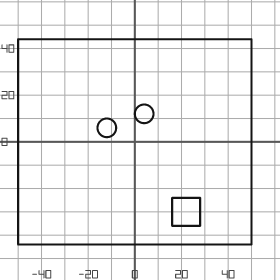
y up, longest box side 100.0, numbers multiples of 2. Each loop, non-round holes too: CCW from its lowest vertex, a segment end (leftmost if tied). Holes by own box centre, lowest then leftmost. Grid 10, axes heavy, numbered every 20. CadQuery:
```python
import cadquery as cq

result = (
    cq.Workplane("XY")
    .moveTo(-50.0, -44.0)
    .lineTo(50.0, -44.0)
    .lineTo(50.0, 44.0)
    .lineTo(-50.0, 44.0)
    .close()
    .moveTo(16.0, -36.0)
    .lineTo(28.0, -36.0)
    .lineTo(28.0, -24.0)
    .lineTo(16.0, -24.0)
    .close()
    .moveTo(-12.0, 6.0)
    .circle(4.0)
    .moveTo(4.0, 12.0)
    .circle(4.0)
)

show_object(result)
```